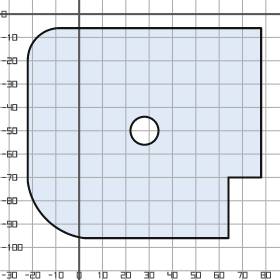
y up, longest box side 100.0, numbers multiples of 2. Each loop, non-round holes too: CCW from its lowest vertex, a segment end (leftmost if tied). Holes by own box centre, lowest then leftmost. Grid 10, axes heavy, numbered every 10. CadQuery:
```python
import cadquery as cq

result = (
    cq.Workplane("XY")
    .moveTo(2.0, -96.0)
    .lineTo(64.0, -96.0)
    .lineTo(64.0, -70.0)
    .lineTo(78.0, -70.0)
    .lineTo(78.0, -6.0)
    .lineTo(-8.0, -6.0)
    .threePointArc((-18.0, -10.0), (-22.0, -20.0))
    .lineTo(-22.0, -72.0)
    .threePointArc((-14.0, -88.0), (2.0, -96.0))
    .close()
    .moveTo(28.0, -50.0)
    .circle(6.0)
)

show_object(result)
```